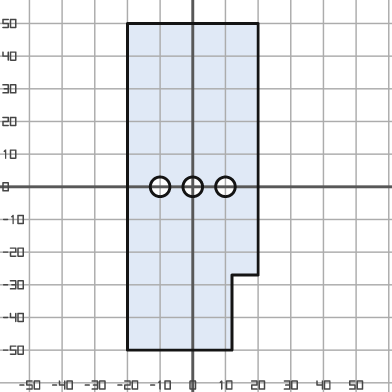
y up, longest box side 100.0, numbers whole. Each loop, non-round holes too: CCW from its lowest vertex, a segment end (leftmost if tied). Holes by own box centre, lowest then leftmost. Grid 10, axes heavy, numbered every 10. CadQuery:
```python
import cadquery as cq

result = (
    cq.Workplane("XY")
    .moveTo(-20.0, -50.0)
    .lineTo(12.0, -50.0)
    .lineTo(12.0, -27.0)
    .lineTo(20.0, -27.0)
    .lineTo(20.0, 50.0)
    .lineTo(-20.0, 50.0)
    .close()
    .moveTo(-10.0, 0.0)
    .circle(3.0)
    .moveTo(0.0, 0.0)
    .circle(3.0)
    .moveTo(10.0, 0.0)
    .circle(3.0)
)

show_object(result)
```